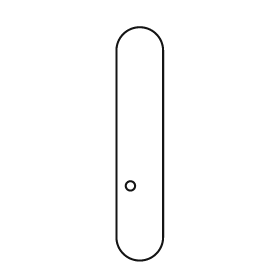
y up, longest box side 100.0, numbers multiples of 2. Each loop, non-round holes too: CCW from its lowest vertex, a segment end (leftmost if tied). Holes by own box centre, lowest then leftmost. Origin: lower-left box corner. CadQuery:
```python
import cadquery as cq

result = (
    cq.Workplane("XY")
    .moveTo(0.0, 10.0)
    .threePointArc((10.0, 0.0), (20.0, 10.0))
    .lineTo(20.0, 90.0)
    .threePointArc((10.0, 100.0), (0.0, 90.0))
    .close()
    .moveTo(6.0, 32.0)
    .circle(2.0)
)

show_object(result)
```